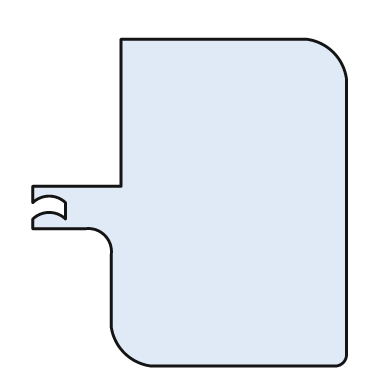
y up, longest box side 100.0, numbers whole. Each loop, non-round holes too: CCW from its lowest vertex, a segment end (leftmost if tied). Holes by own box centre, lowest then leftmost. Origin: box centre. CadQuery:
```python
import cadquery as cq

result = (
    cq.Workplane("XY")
    .moveTo(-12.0, -50.0)
    .lineTo(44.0, -50.0)
    .threePointArc((47.0, -49.0), (48.0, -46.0))
    .lineTo(48.0, 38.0)
    .threePointArc((44.0, 46.0), (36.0, 50.0))
    .lineTo(-21.0, 50.0)
    .lineTo(-21.0, 5.0)
    .lineTo(-48.0, 5.0)
    .lineTo(-48.0, 0.0)
    .threePointArc((-43.0, 2.0), (-38.0, 0.0))
    .lineTo(-38.0, -5.0)
    .threePointArc((-43.0, -3.0), (-48.0, -5.0))
    .lineTo(-48.0, -8.0)
    .lineTo(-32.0, -8.0)
    .threePointArc((-26.0, -10.0), (-24.0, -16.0))
    .lineTo(-24.0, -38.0)
    .threePointArc((-20.0, -46.0), (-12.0, -50.0))
    .close()
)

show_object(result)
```